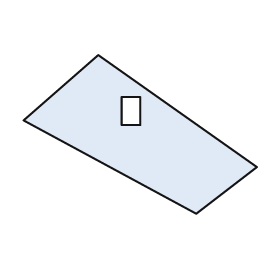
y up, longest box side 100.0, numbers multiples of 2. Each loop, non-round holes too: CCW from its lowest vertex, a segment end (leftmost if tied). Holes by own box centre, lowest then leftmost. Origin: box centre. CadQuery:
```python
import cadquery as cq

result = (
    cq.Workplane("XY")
    .moveTo(24.0, -34.0)
    .lineTo(50.0, -14.0)
    .lineTo(-18.0, 34.0)
    .lineTo(-50.0, 6.0)
    .close()
    .moveTo(-8.0, 4.0)
    .lineTo(0.0, 4.0)
    .lineTo(0.0, 16.0)
    .lineTo(-8.0, 16.0)
    .close()
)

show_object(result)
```